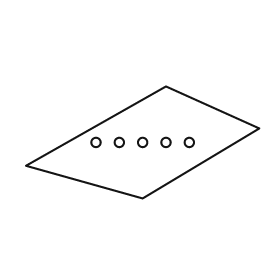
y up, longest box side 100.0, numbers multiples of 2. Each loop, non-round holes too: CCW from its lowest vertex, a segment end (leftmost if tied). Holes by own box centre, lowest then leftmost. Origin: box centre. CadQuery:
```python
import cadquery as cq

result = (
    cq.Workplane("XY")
    .moveTo(0.0, -24.0)
    .lineTo(50.0, 6.0)
    .lineTo(10.0, 24.0)
    .lineTo(-50.0, -10.0)
    .close()
    .moveTo(-20.0, 0.0)
    .circle(2.0)
    .moveTo(-10.0, 0.0)
    .circle(2.0)
    .moveTo(0.0, 0.0)
    .circle(2.0)
    .moveTo(10.0, 0.0)
    .circle(2.0)
    .moveTo(20.0, 0.0)
    .circle(2.0)
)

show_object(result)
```